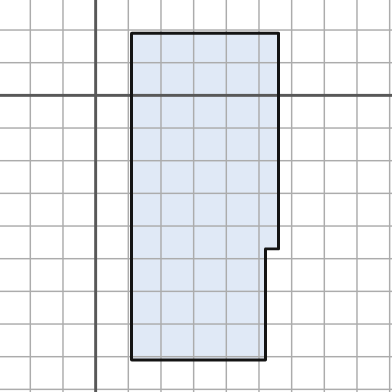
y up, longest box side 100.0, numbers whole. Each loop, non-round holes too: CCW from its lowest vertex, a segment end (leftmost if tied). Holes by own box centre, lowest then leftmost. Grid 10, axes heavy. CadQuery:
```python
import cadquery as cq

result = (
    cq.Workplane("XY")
    .moveTo(11.0, -81.0)
    .lineTo(52.0, -81.0)
    .lineTo(52.0, -47.0)
    .lineTo(56.0, -47.0)
    .lineTo(56.0, 19.0)
    .lineTo(11.0, 19.0)
    .close()
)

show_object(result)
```